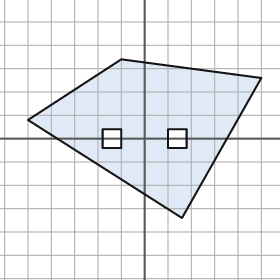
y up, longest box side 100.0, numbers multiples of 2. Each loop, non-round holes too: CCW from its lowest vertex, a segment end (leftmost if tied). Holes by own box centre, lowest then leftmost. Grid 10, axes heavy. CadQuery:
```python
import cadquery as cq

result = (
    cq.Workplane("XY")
    .moveTo(16.0, -34.0)
    .lineTo(50.0, 26.0)
    .lineTo(-10.0, 34.0)
    .lineTo(-50.0, 8.0)
    .close()
    .moveTo(-18.0, -4.0)
    .lineTo(-10.0, -4.0)
    .lineTo(-10.0, 4.0)
    .lineTo(-18.0, 4.0)
    .close()
    .moveTo(10.0, -4.0)
    .lineTo(18.0, -4.0)
    .lineTo(18.0, 4.0)
    .lineTo(10.0, 4.0)
    .close()
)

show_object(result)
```